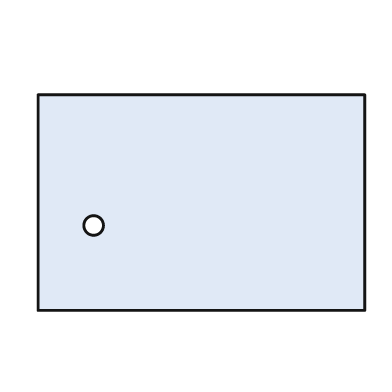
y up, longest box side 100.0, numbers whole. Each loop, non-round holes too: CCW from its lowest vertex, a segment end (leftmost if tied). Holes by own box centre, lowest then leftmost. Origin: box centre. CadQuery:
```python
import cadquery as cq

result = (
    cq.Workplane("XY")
    .moveTo(-50.0, -33.0)
    .lineTo(50.0, -33.0)
    .lineTo(50.0, 33.0)
    .lineTo(-50.0, 33.0)
    .close()
    .moveTo(-33.0, -7.0)
    .circle(3.0)
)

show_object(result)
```